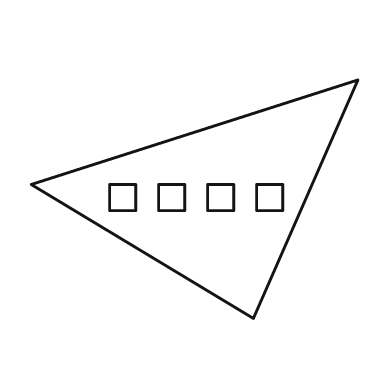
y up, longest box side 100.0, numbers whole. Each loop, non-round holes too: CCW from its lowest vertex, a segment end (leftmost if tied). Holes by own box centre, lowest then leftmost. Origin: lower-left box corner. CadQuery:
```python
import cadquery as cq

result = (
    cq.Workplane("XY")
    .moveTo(68.0, 0.0)
    .lineTo(100.0, 73.0)
    .lineTo(0.0, 41.0)
    .close()
    .moveTo(24.0, 33.0)
    .lineTo(32.0, 33.0)
    .lineTo(32.0, 41.0)
    .lineTo(24.0, 41.0)
    .close()
    .moveTo(39.0, 33.0)
    .lineTo(47.0, 33.0)
    .lineTo(47.0, 41.0)
    .lineTo(39.0, 41.0)
    .close()
    .moveTo(54.0, 33.0)
    .lineTo(62.0, 33.0)
    .lineTo(62.0, 41.0)
    .lineTo(54.0, 41.0)
    .close()
    .moveTo(69.0, 33.0)
    .lineTo(77.0, 33.0)
    .lineTo(77.0, 41.0)
    .lineTo(69.0, 41.0)
    .close()
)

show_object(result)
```